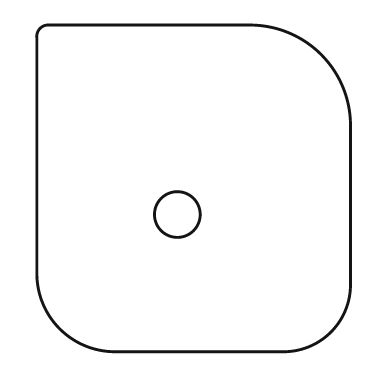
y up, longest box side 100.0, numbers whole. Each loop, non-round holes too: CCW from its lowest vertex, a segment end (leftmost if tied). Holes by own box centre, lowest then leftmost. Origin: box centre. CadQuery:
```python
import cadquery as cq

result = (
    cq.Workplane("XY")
    .moveTo(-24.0, -50.0)
    .lineTo(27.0, -50.0)
    .threePointArc((42.0, -44.0), (48.0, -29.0))
    .lineTo(48.0, 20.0)
    .threePointArc((39.0, 41.0), (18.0, 50.0))
    .lineTo(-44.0, 50.0)
    .threePointArc((-47.0, 49.0), (-48.0, 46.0))
    .lineTo(-48.0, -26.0)
    .threePointArc((-41.0, -43.0), (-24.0, -50.0))
    .close()
    .moveTo(-5.0, -8.0)
    .circle(7.0)
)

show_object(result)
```